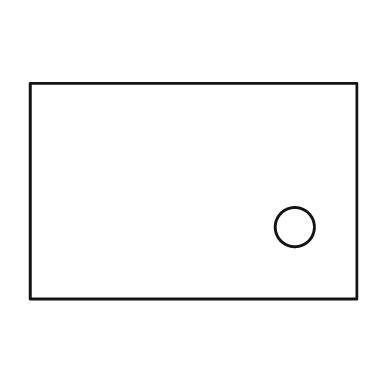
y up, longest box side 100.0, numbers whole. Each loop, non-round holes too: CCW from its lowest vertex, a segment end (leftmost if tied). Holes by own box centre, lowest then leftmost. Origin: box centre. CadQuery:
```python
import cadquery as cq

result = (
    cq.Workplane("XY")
    .moveTo(-50.0, -33.0)
    .lineTo(50.0, -33.0)
    .lineTo(50.0, 33.0)
    .lineTo(-50.0, 33.0)
    .close()
    .moveTo(31.0, -11.0)
    .circle(6.0)
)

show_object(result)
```